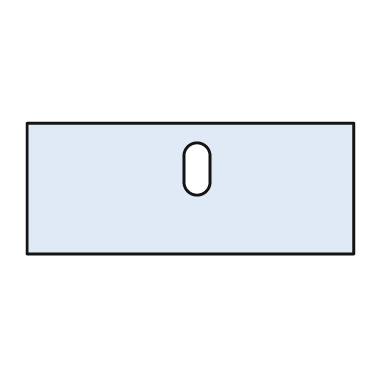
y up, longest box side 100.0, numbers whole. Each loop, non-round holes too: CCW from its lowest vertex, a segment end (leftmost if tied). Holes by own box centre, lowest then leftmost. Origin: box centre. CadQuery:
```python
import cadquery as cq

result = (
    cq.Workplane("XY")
    .moveTo(-50.0, -20.0)
    .lineTo(50.0, -20.0)
    .lineTo(50.0, 20.0)
    .lineTo(-50.0, 20.0)
    .close()
    .moveTo(-2.0, 2.0)
    .threePointArc((2.0, -2.0), (6.0, 2.0))
    .lineTo(6.0, 10.0)
    .threePointArc((2.0, 14.0), (-2.0, 10.0))
    .close()
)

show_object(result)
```